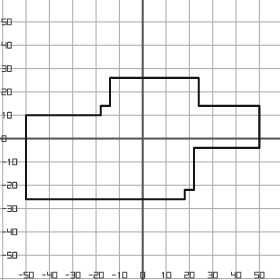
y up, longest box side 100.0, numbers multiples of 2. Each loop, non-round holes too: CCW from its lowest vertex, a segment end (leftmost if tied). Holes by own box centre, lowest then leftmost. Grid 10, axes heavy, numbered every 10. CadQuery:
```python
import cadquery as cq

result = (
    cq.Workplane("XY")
    .moveTo(-50.0, -26.0)
    .lineTo(18.0, -26.0)
    .lineTo(18.0, -22.0)
    .lineTo(22.0, -22.0)
    .lineTo(22.0, -4.0)
    .lineTo(50.0, -4.0)
    .lineTo(50.0, 14.0)
    .lineTo(24.0, 14.0)
    .lineTo(24.0, 26.0)
    .lineTo(-14.0, 26.0)
    .lineTo(-14.0, 14.0)
    .lineTo(-18.0, 14.0)
    .lineTo(-18.0, 10.0)
    .lineTo(-50.0, 10.0)
    .close()
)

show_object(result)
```